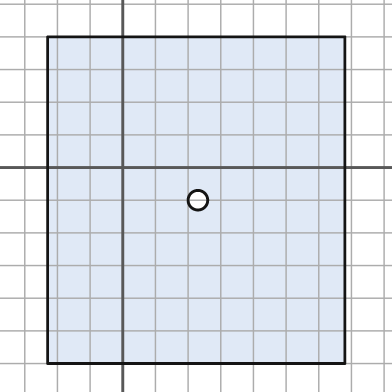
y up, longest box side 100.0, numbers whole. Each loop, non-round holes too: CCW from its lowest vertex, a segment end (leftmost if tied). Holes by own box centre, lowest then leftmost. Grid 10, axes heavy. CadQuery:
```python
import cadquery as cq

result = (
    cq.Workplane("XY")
    .moveTo(-23.0, -60.0)
    .lineTo(68.0, -60.0)
    .lineTo(68.0, 40.0)
    .lineTo(-23.0, 40.0)
    .close()
    .moveTo(23.0, -10.0)
    .circle(3.0)
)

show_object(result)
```